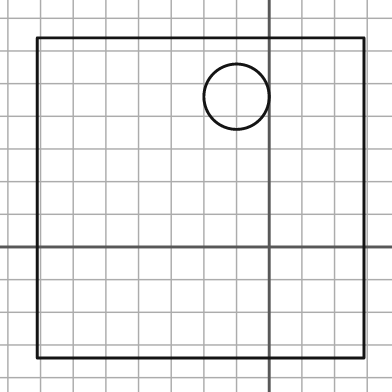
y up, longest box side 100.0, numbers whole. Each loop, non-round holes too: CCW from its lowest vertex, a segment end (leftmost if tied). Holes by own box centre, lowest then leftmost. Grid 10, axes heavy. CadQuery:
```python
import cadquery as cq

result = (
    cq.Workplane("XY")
    .moveTo(-71.0, -34.0)
    .lineTo(29.0, -34.0)
    .lineTo(29.0, 64.0)
    .lineTo(-71.0, 64.0)
    .close()
    .moveTo(-10.0, 46.0)
    .circle(10.0)
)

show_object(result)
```